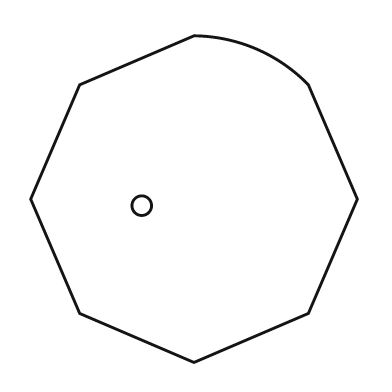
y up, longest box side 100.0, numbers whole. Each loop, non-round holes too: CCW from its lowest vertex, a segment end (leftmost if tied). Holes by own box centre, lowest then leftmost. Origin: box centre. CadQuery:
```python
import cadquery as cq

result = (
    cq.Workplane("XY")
    .moveTo(0.0, -50.0)
    .lineTo(35.0, -35.0)
    .lineTo(50.0, 0.0)
    .lineTo(35.0, 35.0)
    .threePointArc((19.0, 46.0), (0.0, 50.0))
    .lineTo(-35.0, 35.0)
    .lineTo(-50.0, 0.0)
    .lineTo(-35.0, -35.0)
    .close()
    .moveTo(-16.0, -2.0)
    .circle(3.0)
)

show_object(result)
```